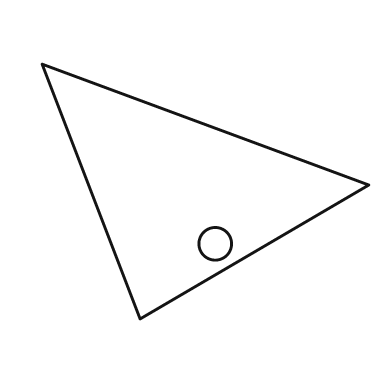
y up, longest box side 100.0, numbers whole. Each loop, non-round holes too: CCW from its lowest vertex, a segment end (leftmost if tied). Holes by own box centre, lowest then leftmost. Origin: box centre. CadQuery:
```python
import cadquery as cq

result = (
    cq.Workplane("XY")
    .moveTo(-20.0, -39.0)
    .lineTo(50.0, 2.0)
    .lineTo(-50.0, 39.0)
    .close()
    .moveTo(3.0, -16.0)
    .circle(5.0)
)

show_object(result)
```